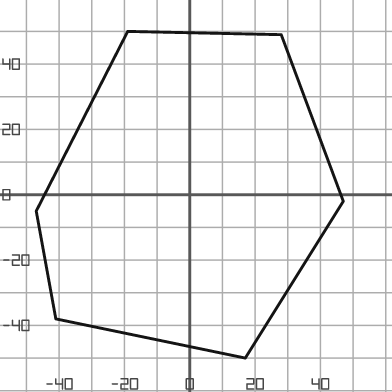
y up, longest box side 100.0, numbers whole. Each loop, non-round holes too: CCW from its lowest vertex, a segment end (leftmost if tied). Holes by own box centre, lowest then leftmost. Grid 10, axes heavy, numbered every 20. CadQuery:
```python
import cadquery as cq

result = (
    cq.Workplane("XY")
    .moveTo(17.0, -50.0)
    .lineTo(47.0, -2.0)
    .lineTo(28.0, 49.0)
    .lineTo(-19.0, 50.0)
    .lineTo(-47.0, -5.0)
    .lineTo(-41.0, -38.0)
    .close()
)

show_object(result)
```